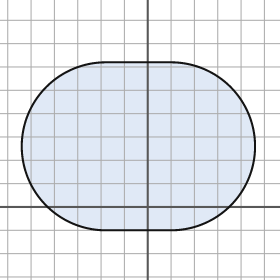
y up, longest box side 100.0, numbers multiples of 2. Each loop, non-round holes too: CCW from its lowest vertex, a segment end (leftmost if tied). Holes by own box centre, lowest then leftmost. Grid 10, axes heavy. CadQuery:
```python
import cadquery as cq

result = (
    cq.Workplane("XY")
    .moveTo(-18.0, -10.0)
    .lineTo(10.0, -10.0)
    .threePointArc((46.0, 26.0), (10.0, 62.0))
    .lineTo(-18.0, 62.0)
    .threePointArc((-54.0, 26.0), (-18.0, -10.0))
    .close()
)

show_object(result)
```